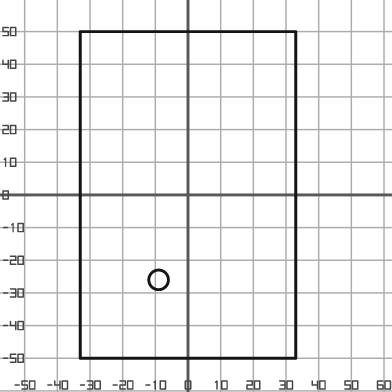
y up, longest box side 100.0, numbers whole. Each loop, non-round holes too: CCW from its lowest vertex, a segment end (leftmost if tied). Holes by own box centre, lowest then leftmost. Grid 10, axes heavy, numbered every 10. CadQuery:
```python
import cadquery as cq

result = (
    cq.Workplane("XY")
    .moveTo(-33.0, -50.0)
    .lineTo(33.0, -50.0)
    .lineTo(33.0, 50.0)
    .lineTo(-33.0, 50.0)
    .close()
    .moveTo(-9.0, -26.0)
    .circle(3.0)
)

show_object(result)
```